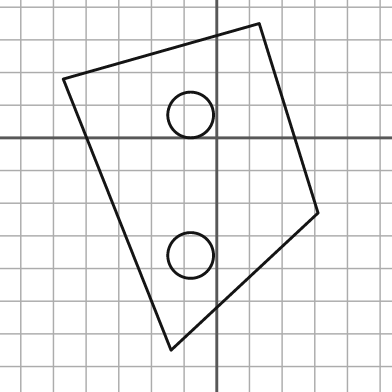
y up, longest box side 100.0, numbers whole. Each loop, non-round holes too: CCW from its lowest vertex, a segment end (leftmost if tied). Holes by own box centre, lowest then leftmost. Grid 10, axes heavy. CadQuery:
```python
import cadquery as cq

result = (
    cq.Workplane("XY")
    .moveTo(-14.0, -65.0)
    .lineTo(31.0, -23.0)
    .lineTo(13.0, 35.0)
    .lineTo(-47.0, 18.0)
    .close()
    .moveTo(-8.0, -36.0)
    .circle(7.0)
    .moveTo(-8.0, 7.0)
    .circle(7.0)
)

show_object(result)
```